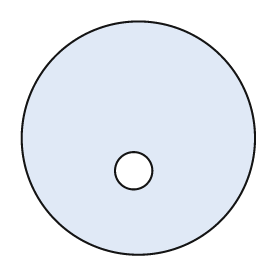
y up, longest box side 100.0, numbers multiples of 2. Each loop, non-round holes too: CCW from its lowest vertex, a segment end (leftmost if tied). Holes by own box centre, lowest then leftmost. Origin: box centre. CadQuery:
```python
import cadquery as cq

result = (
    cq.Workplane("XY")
    .moveTo(0.0, 0.0)
    .circle(50.0)
    .moveTo(-2.0, -14.0)
    .circle(8.0)
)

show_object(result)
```